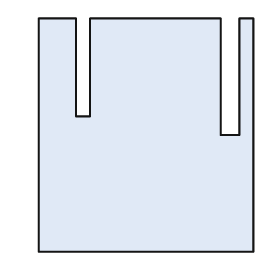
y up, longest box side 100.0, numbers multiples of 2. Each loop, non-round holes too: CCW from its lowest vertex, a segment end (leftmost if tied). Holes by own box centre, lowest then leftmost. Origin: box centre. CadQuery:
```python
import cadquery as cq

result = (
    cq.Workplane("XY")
    .moveTo(-46.0, -50.0)
    .lineTo(46.0, -50.0)
    .lineTo(46.0, 50.0)
    .lineTo(40.0, 50.0)
    .lineTo(40.0, 0.0)
    .lineTo(32.0, 0.0)
    .lineTo(32.0, 50.0)
    .lineTo(-24.0, 50.0)
    .lineTo(-24.0, 8.0)
    .lineTo(-30.0, 8.0)
    .lineTo(-30.0, 50.0)
    .lineTo(-46.0, 50.0)
    .close()
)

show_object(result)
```